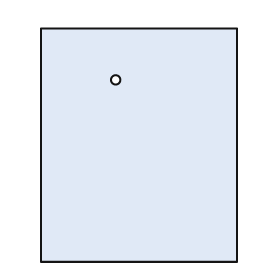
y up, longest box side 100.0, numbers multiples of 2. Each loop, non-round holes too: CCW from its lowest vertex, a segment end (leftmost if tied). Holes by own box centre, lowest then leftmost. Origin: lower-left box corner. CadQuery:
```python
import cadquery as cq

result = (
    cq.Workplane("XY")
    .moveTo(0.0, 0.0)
    .lineTo(84.0, 0.0)
    .lineTo(84.0, 100.0)
    .lineTo(0.0, 100.0)
    .close()
    .moveTo(32.0, 78.0)
    .circle(2.0)
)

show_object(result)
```